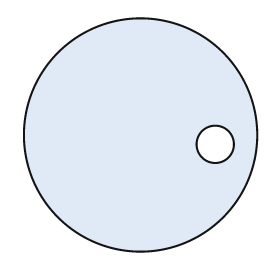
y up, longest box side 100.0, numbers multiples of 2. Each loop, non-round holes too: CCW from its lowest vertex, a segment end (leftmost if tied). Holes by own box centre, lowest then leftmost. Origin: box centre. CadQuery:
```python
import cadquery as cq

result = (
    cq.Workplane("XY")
    .moveTo(0.0, 0.0)
    .circle(50.0)
    .moveTo(32.0, -4.0)
    .circle(8.0)
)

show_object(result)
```